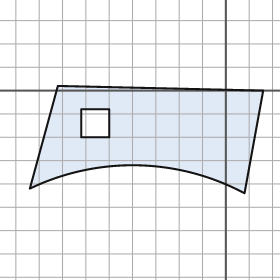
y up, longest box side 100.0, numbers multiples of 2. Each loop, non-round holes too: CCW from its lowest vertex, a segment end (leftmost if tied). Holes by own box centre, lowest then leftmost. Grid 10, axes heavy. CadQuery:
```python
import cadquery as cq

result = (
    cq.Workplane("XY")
    .moveTo(8.0, -44.0)
    .lineTo(16.0, 0.0)
    .lineTo(-72.0, 2.0)
    .lineTo(-84.0, -42.0)
    .threePointArc((-38.0, -32.0), (8.0, -44.0))
    .close()
    .moveTo(-62.0, -20.0)
    .lineTo(-50.0, -20.0)
    .lineTo(-50.0, -8.0)
    .lineTo(-62.0, -8.0)
    .close()
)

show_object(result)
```